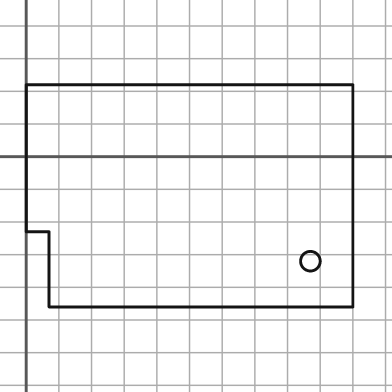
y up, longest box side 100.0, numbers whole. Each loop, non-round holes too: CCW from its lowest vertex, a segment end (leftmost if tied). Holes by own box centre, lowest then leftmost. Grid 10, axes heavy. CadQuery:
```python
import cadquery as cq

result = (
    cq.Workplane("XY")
    .moveTo(7.0, -46.0)
    .lineTo(100.0, -46.0)
    .lineTo(100.0, 22.0)
    .lineTo(0.0, 22.0)
    .lineTo(0.0, -23.0)
    .lineTo(7.0, -23.0)
    .close()
    .moveTo(87.0, -32.0)
    .circle(3.0)
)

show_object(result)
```